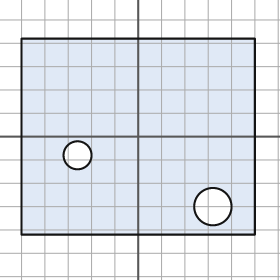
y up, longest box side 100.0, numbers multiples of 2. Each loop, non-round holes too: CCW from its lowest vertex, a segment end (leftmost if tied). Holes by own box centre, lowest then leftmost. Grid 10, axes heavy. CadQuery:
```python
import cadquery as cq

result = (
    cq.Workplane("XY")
    .moveTo(-50.0, -42.0)
    .lineTo(50.0, -42.0)
    .lineTo(50.0, 42.0)
    .lineTo(-50.0, 42.0)
    .close()
    .moveTo(32.0, -30.0)
    .circle(8.0)
    .moveTo(-26.0, -8.0)
    .circle(6.0)
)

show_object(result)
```